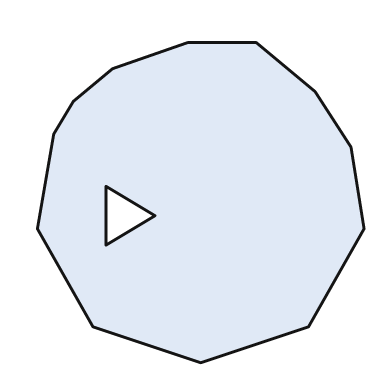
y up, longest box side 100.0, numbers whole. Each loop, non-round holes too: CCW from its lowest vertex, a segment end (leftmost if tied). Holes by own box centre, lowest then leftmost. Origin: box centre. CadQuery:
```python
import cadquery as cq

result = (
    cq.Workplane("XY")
    .moveTo(0.0, -49.0)
    .lineTo(33.0, -38.0)
    .lineTo(50.0, -8.0)
    .lineTo(46.0, 17.0)
    .lineTo(35.0, 34.0)
    .lineTo(17.0, 49.0)
    .lineTo(-4.0, 49.0)
    .lineTo(-27.0, 41.0)
    .lineTo(-39.0, 31.0)
    .lineTo(-45.0, 21.0)
    .lineTo(-50.0, -8.0)
    .lineTo(-33.0, -38.0)
    .close()
    .moveTo(-29.0, -13.0)
    .lineTo(-14.0, -4.0)
    .lineTo(-29.0, 5.0)
    .close()
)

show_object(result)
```